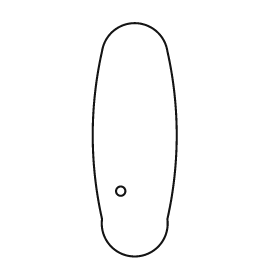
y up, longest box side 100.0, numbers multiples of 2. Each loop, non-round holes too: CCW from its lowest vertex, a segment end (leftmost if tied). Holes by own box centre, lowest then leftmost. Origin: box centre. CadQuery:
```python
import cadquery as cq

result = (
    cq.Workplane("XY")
    .moveTo(-14.0, -34.0)
    .threePointArc((0.0, -50.0), (14.0, -34.0))
    .threePointArc((18.0, 2.0), (14.0, 38.0))
    .threePointArc((0.0, 50.0), (-14.0, 38.0))
    .threePointArc((-18.0, 2.0), (-14.0, -34.0))
    .close()
    .moveTo(-6.0, -22.0)
    .circle(2.0)
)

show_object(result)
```